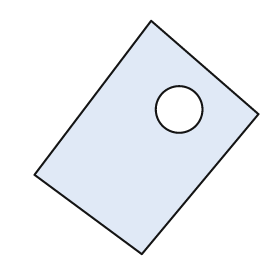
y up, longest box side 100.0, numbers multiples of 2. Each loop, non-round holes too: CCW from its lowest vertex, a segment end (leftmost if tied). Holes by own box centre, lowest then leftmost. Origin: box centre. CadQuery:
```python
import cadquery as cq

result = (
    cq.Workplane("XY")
    .moveTo(-2.0, -50.0)
    .lineTo(48.0, 10.0)
    .lineTo(2.0, 50.0)
    .lineTo(-48.0, -16.0)
    .close()
    .moveTo(14.0, 12.0)
    .circle(10.0)
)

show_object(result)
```